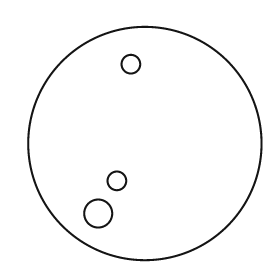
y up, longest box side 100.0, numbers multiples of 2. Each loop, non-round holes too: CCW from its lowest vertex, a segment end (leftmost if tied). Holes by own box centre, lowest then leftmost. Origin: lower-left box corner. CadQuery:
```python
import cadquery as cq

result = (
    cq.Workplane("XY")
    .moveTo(50.0, 50.0)
    .circle(50.0)
    .moveTo(30.0, 20.0)
    .circle(6.0)
    .moveTo(38.0, 34.0)
    .circle(4.0)
    .moveTo(44.0, 84.0)
    .circle(4.0)
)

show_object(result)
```